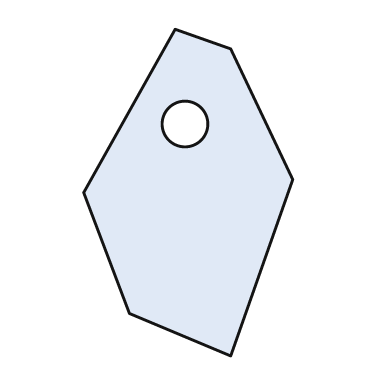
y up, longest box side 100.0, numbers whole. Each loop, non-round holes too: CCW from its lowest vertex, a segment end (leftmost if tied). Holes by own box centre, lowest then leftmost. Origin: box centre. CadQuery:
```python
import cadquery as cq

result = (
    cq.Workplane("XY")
    .moveTo(13.0, -50.0)
    .lineTo(32.0, 4.0)
    .lineTo(13.0, 44.0)
    .lineTo(-4.0, 50.0)
    .lineTo(-32.0, 0.0)
    .lineTo(-18.0, -37.0)
    .close()
    .moveTo(-1.0, 21.0)
    .circle(7.0)
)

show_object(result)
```